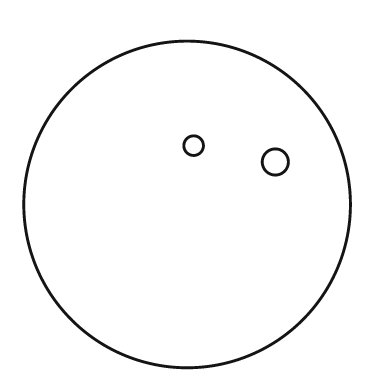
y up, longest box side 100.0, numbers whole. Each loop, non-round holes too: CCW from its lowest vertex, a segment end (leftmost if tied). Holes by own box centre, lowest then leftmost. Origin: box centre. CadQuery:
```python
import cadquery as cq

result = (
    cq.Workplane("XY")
    .moveTo(0.0, 0.0)
    .circle(50.0)
    .moveTo(27.0, 13.0)
    .circle(4.0)
    .moveTo(2.0, 18.0)
    .circle(3.0)
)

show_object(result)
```